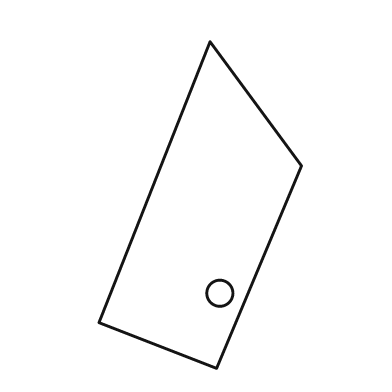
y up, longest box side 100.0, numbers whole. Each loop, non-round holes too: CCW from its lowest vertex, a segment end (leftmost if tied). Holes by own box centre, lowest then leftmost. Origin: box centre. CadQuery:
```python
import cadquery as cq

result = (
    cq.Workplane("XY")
    .moveTo(5.0, -50.0)
    .lineTo(31.0, 12.0)
    .lineTo(3.0, 50.0)
    .lineTo(-31.0, -36.0)
    .close()
    .moveTo(6.0, -27.0)
    .circle(4.0)
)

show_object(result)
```